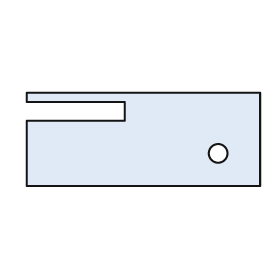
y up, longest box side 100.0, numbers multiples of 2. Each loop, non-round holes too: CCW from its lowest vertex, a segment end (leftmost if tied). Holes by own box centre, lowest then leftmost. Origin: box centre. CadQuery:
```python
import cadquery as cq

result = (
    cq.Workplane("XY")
    .moveTo(-50.0, -20.0)
    .lineTo(50.0, -20.0)
    .lineTo(50.0, 20.0)
    .lineTo(-50.0, 20.0)
    .lineTo(-50.0, 16.0)
    .lineTo(-8.0, 16.0)
    .lineTo(-8.0, 8.0)
    .lineTo(-50.0, 8.0)
    .close()
    .moveTo(32.0, -6.0)
    .circle(4.0)
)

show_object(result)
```